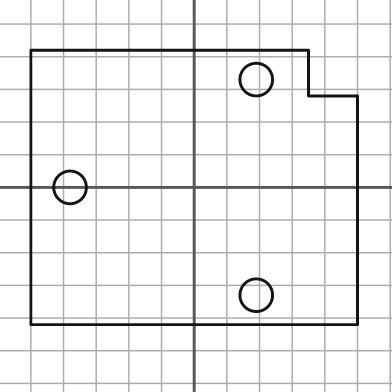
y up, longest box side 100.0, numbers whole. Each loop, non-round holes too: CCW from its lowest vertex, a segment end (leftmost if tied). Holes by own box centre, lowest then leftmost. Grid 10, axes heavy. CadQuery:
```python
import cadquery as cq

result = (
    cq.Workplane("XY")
    .moveTo(-50.0, -42.0)
    .lineTo(50.0, -42.0)
    .lineTo(50.0, 28.0)
    .lineTo(35.0, 28.0)
    .lineTo(35.0, 42.0)
    .lineTo(-50.0, 42.0)
    .close()
    .moveTo(19.0, -33.0)
    .circle(5.0)
    .moveTo(-38.0, 0.0)
    .circle(5.0)
    .moveTo(19.0, 33.0)
    .circle(5.0)
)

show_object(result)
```